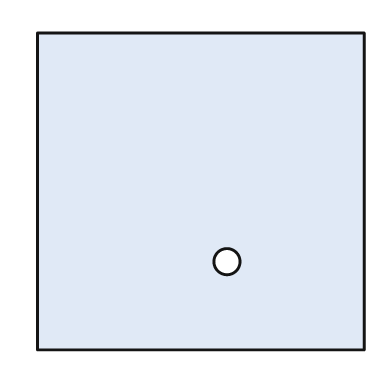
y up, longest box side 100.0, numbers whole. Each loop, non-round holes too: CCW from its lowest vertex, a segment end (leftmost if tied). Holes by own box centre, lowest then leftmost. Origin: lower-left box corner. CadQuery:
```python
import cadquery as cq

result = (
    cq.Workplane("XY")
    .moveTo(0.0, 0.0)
    .lineTo(100.0, 0.0)
    .lineTo(100.0, 97.0)
    .lineTo(0.0, 97.0)
    .close()
    .moveTo(58.0, 27.0)
    .circle(4.0)
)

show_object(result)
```